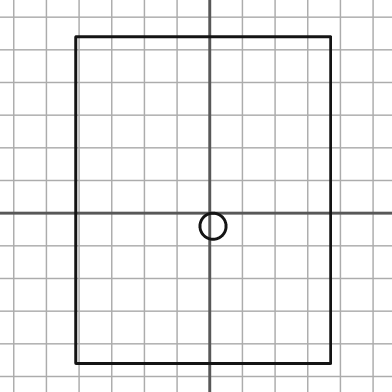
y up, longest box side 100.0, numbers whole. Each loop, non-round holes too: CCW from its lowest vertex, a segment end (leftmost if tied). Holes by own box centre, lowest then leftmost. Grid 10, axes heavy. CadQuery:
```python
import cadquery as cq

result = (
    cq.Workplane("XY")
    .moveTo(-41.0, -46.0)
    .lineTo(37.0, -46.0)
    .lineTo(37.0, 54.0)
    .lineTo(-41.0, 54.0)
    .close()
    .moveTo(1.0, -4.0)
    .circle(4.0)
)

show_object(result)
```